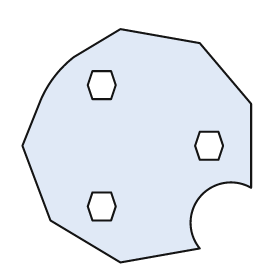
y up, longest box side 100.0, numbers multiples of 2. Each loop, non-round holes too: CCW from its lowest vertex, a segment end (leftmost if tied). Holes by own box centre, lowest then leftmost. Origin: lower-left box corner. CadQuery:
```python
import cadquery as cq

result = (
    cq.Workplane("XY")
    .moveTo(42.0, 0.0)
    .lineTo(76.0, 6.0)
    .threePointArc((76.0, 28.0), (98.0, 32.0))
    .lineTo(98.0, 68.0)
    .lineTo(76.0, 94.0)
    .lineTo(42.0, 100.0)
    .lineTo(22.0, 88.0)
    .threePointArc((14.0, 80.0), (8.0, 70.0))
    .lineTo(0.0, 50.0)
    .lineTo(12.0, 18.0)
    .close()
    .moveTo(30.0, 18.0)
    .lineTo(38.0, 18.0)
    .lineTo(40.0, 24.0)
    .lineTo(38.0, 30.0)
    .lineTo(30.0, 30.0)
    .lineTo(28.0, 24.0)
    .close()
    .moveTo(76.0, 44.0)
    .lineTo(84.0, 44.0)
    .lineTo(86.0, 50.0)
    .lineTo(84.0, 56.0)
    .lineTo(76.0, 56.0)
    .lineTo(74.0, 50.0)
    .close()
    .moveTo(30.0, 70.0)
    .lineTo(38.0, 70.0)
    .lineTo(40.0, 76.0)
    .lineTo(38.0, 82.0)
    .lineTo(30.0, 82.0)
    .lineTo(28.0, 76.0)
    .close()
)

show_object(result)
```